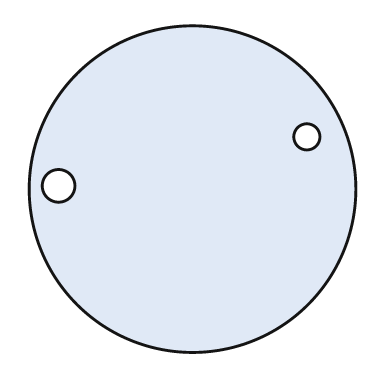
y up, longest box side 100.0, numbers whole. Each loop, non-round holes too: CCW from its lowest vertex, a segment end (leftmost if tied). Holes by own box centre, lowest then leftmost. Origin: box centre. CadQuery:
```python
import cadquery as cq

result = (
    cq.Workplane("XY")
    .moveTo(0.0, 0.0)
    .circle(50.0)
    .moveTo(-41.0, 1.0)
    .circle(5.0)
    .moveTo(35.0, 16.0)
    .circle(4.0)
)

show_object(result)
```